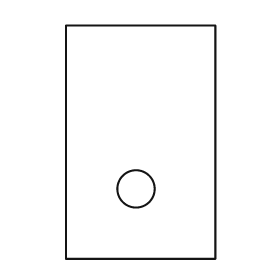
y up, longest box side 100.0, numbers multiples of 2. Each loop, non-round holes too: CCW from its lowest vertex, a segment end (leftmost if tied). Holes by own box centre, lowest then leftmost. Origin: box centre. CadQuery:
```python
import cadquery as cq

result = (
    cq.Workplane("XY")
    .moveTo(-32.0, -50.0)
    .lineTo(32.0, -50.0)
    .lineTo(32.0, 50.0)
    .lineTo(-32.0, 50.0)
    .close()
    .moveTo(-2.0, -20.0)
    .circle(8.0)
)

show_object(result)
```